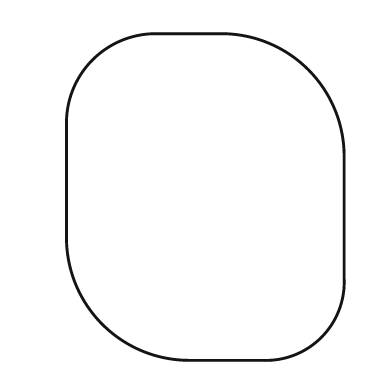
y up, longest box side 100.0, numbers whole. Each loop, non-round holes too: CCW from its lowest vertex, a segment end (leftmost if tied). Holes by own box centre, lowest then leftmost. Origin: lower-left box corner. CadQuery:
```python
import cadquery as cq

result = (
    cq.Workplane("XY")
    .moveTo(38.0, 0.0)
    .lineTo(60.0, 0.0)
    .threePointArc((78.0, 7.0), (85.0, 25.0))
    .lineTo(85.0, 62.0)
    .threePointArc((74.0, 89.0), (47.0, 100.0))
    .lineTo(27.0, 100.0)
    .threePointArc((8.0, 92.0), (0.0, 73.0))
    .lineTo(0.0, 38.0)
    .threePointArc((11.0, 11.0), (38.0, 0.0))
    .close()
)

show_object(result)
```